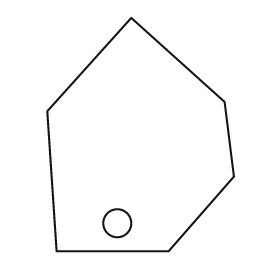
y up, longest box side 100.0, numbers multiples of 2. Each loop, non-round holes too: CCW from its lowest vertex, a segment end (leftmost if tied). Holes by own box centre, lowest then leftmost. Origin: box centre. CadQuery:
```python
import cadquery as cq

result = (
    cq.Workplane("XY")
    .moveTo(-36.0, -50.0)
    .lineTo(12.0, -50.0)
    .lineTo(40.0, -18.0)
    .lineTo(36.0, 14.0)
    .lineTo(-4.0, 50.0)
    .lineTo(-40.0, 10.0)
    .close()
    .moveTo(-10.0, -38.0)
    .circle(6.0)
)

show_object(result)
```